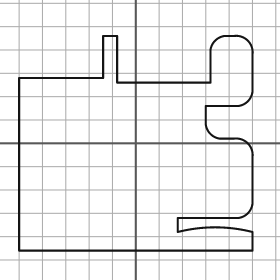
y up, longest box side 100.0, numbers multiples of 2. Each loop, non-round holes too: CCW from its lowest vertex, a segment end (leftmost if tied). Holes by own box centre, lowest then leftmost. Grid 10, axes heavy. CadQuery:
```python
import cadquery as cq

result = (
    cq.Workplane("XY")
    .moveTo(-50.0, -46.0)
    .lineTo(50.0, -46.0)
    .lineTo(50.0, -38.0)
    .threePointArc((34.0, -36.0), (18.0, -38.0))
    .lineTo(18.0, -32.0)
    .lineTo(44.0, -32.0)
    .threePointArc((48.0, -30.0), (50.0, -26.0))
    .lineTo(50.0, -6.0)
    .threePointArc((48.0, 0.0), (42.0, 2.0))
    .lineTo(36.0, 2.0)
    .threePointArc((32.0, 4.0), (30.0, 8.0))
    .lineTo(30.0, 16.0)
    .lineTo(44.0, 16.0)
    .threePointArc((48.0, 18.0), (50.0, 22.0))
    .lineTo(50.0, 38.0)
    .threePointArc((48.0, 44.0), (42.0, 46.0))
    .lineTo(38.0, 46.0)
    .threePointArc((34.0, 44.0), (32.0, 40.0))
    .lineTo(32.0, 26.0)
    .lineTo(-8.0, 26.0)
    .lineTo(-8.0, 46.0)
    .lineTo(-14.0, 46.0)
    .lineTo(-14.0, 28.0)
    .lineTo(-50.0, 28.0)
    .close()
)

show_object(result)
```